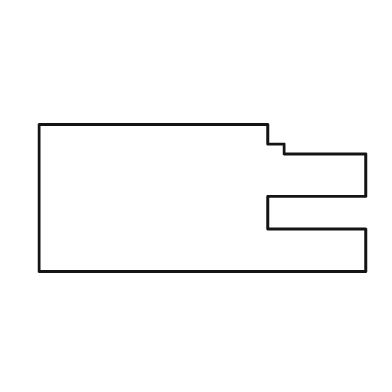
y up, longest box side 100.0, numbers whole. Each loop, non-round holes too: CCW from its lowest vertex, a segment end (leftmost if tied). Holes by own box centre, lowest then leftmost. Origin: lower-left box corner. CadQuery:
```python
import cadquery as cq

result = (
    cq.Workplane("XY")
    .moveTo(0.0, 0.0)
    .lineTo(100.0, 0.0)
    .lineTo(100.0, 13.0)
    .lineTo(70.0, 13.0)
    .lineTo(70.0, 23.0)
    .lineTo(100.0, 23.0)
    .lineTo(100.0, 36.0)
    .lineTo(75.0, 36.0)
    .lineTo(75.0, 39.0)
    .lineTo(70.0, 39.0)
    .lineTo(70.0, 45.0)
    .lineTo(0.0, 45.0)
    .close()
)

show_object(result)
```